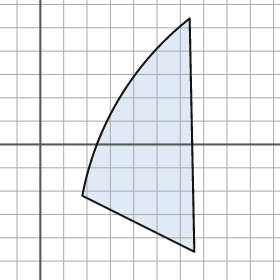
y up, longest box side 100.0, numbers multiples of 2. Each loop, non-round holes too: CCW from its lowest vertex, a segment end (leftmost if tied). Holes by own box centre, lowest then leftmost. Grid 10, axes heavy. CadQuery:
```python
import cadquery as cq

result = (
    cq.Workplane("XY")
    .moveTo(66.0, -46.0)
    .lineTo(64.0, 54.0)
    .threePointArc((34.0, 20.0), (18.0, -22.0))
    .close()
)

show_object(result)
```